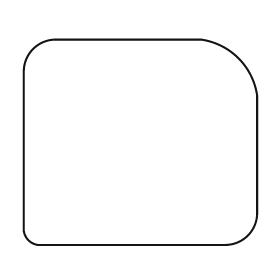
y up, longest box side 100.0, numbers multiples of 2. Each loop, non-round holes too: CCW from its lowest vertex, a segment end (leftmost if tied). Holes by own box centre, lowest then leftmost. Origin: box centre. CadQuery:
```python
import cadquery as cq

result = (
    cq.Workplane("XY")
    .moveTo(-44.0, -44.0)
    .lineTo(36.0, -44.0)
    .threePointArc((46.0, -40.0), (50.0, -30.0))
    .lineTo(50.0, 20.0)
    .threePointArc((42.0, 36.0), (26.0, 44.0))
    .lineTo(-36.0, 44.0)
    .threePointArc((-46.0, 40.0), (-50.0, 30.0))
    .lineTo(-50.0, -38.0)
    .threePointArc((-48.0, -42.0), (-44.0, -44.0))
    .close()
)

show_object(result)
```